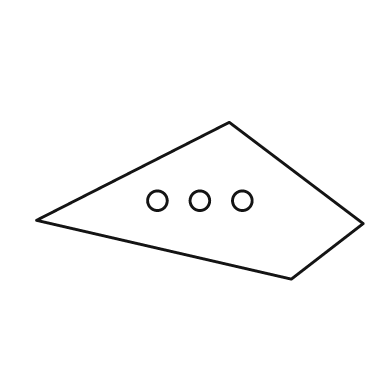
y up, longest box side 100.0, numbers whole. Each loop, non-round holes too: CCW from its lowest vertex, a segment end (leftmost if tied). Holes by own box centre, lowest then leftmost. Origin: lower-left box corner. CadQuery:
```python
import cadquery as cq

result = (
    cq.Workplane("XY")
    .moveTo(78.0, 0.0)
    .lineTo(100.0, 17.0)
    .lineTo(59.0, 48.0)
    .lineTo(0.0, 18.0)
    .close()
    .moveTo(37.0, 24.0)
    .circle(3.0)
    .moveTo(50.0, 24.0)
    .circle(3.0)
    .moveTo(63.0, 24.0)
    .circle(3.0)
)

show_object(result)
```